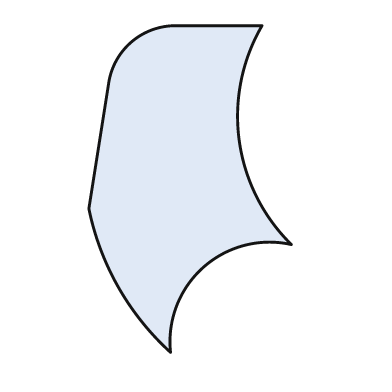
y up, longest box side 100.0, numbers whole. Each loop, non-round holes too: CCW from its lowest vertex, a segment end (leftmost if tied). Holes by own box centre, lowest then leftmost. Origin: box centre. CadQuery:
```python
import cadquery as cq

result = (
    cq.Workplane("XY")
    .moveTo(-6.0, -50.0)
    .threePointArc((4.0, -24.0), (31.0, -17.0))
    .threePointArc((15.0, 15.0), (22.0, 50.0))
    .lineTo(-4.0, 50.0)
    .threePointArc((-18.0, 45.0), (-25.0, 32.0))
    .lineTo(-31.0, -6.0)
    .threePointArc((-22.0, -30.0), (-6.0, -50.0))
    .close()
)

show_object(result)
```